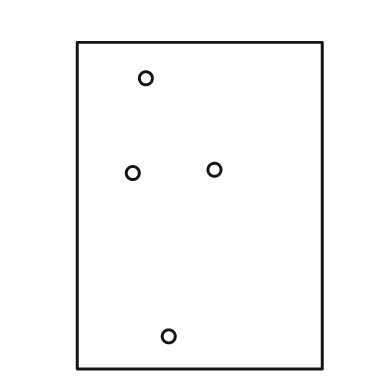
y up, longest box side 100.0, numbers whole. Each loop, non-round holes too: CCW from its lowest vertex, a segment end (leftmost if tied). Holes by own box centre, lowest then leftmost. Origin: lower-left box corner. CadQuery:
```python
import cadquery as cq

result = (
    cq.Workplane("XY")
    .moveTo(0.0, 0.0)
    .lineTo(75.0, 0.0)
    .lineTo(75.0, 100.0)
    .lineTo(0.0, 100.0)
    .close()
    .moveTo(28.0, 10.0)
    .circle(2.0)
    .moveTo(17.0, 60.0)
    .circle(2.0)
    .moveTo(42.0, 61.0)
    .circle(2.0)
    .moveTo(21.0, 89.0)
    .circle(2.0)
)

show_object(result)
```